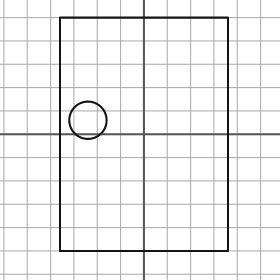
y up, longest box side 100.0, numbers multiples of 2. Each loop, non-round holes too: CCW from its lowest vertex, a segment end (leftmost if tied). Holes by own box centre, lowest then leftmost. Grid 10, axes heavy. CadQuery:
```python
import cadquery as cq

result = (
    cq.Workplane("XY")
    .moveTo(-36.0, -50.0)
    .lineTo(36.0, -50.0)
    .lineTo(36.0, 50.0)
    .lineTo(-36.0, 50.0)
    .close()
    .moveTo(-24.0, 6.0)
    .circle(8.0)
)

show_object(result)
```